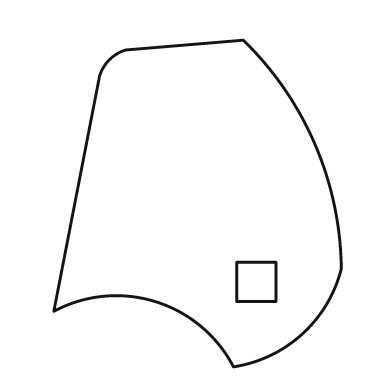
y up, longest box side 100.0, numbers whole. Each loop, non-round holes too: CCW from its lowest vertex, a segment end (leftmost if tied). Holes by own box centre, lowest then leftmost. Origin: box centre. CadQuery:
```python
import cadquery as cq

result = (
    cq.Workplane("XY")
    .moveTo(11.0, -50.0)
    .threePointArc((32.0, -40.0), (44.0, -20.0))
    .threePointArc((36.0, 18.0), (14.0, 50.0))
    .lineTo(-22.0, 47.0)
    .threePointArc((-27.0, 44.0), (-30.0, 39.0))
    .lineTo(-44.0, -33.0)
    .threePointArc((-13.0, -30.0), (11.0, -50.0))
    .close()
    .moveTo(12.0, -30.0)
    .lineTo(24.0, -30.0)
    .lineTo(24.0, -18.0)
    .lineTo(12.0, -18.0)
    .close()
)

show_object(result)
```